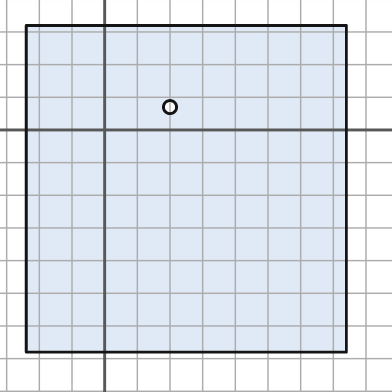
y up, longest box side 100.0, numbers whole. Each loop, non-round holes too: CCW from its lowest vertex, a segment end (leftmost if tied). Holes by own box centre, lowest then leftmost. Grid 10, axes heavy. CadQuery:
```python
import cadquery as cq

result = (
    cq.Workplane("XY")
    .moveTo(-24.0, -68.0)
    .lineTo(74.0, -68.0)
    .lineTo(74.0, 32.0)
    .lineTo(-24.0, 32.0)
    .close()
    .moveTo(20.0, 7.0)
    .circle(2.0)
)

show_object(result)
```